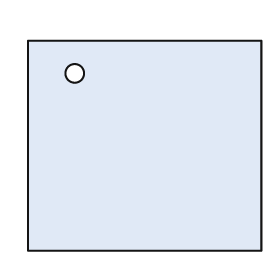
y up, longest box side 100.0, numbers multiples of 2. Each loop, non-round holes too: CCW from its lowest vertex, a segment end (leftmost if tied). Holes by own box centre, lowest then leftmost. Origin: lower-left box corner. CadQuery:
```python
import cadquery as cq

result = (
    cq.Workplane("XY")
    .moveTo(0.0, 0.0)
    .lineTo(100.0, 0.0)
    .lineTo(100.0, 90.0)
    .lineTo(0.0, 90.0)
    .close()
    .moveTo(20.0, 76.0)
    .circle(4.0)
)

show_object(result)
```